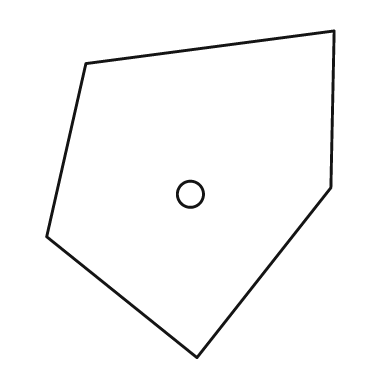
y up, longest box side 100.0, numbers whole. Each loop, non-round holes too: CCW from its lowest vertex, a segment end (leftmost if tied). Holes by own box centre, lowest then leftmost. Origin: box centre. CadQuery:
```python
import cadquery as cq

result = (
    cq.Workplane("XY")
    .moveTo(2.0, -50.0)
    .lineTo(43.0, 2.0)
    .lineTo(44.0, 50.0)
    .lineTo(-32.0, 40.0)
    .lineTo(-44.0, -13.0)
    .close()
    .moveTo(0.0, 0.0)
    .circle(4.0)
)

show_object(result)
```